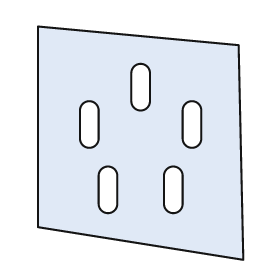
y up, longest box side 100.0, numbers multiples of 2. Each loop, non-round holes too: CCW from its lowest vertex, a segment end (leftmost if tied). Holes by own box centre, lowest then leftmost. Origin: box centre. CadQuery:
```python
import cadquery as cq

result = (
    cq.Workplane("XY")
    .moveTo(44.0, -50.0)
    .lineTo(42.0, 42.0)
    .lineTo(-44.0, 50.0)
    .lineTo(-44.0, -36.0)
    .close()
    .moveTo(-18.0, -26.0)
    .threePointArc((-14.0, -30.0), (-10.0, -26.0))
    .lineTo(-10.0, -14.0)
    .threePointArc((-14.0, -10.0), (-18.0, -14.0))
    .close()
    .moveTo(10.0, -26.0)
    .threePointArc((14.0, -30.0), (18.0, -26.0))
    .lineTo(18.0, -14.0)
    .threePointArc((14.0, -10.0), (10.0, -14.0))
    .close()
    .moveTo(-26.0, 2.0)
    .threePointArc((-22.0, -2.0), (-18.0, 2.0))
    .lineTo(-18.0, 14.0)
    .threePointArc((-22.0, 18.0), (-26.0, 14.0))
    .close()
    .moveTo(18.0, 2.0)
    .threePointArc((22.0, -2.0), (26.0, 2.0))
    .lineTo(26.0, 14.0)
    .threePointArc((22.0, 18.0), (18.0, 14.0))
    .close()
    .moveTo(-4.0, 18.0)
    .threePointArc((0.0, 14.0), (4.0, 18.0))
    .lineTo(4.0, 30.0)
    .threePointArc((0.0, 34.0), (-4.0, 30.0))
    .close()
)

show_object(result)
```